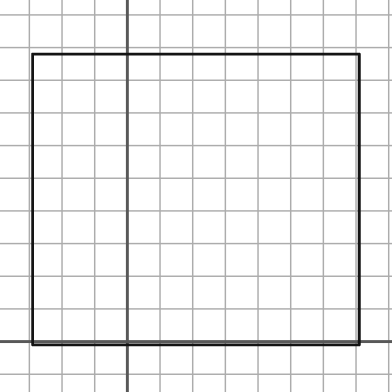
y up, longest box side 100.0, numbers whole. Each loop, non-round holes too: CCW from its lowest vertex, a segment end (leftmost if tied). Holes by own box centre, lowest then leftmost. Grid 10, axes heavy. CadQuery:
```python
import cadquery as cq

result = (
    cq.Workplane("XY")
    .moveTo(-29.0, -1.0)
    .lineTo(71.0, -1.0)
    .lineTo(71.0, 88.0)
    .lineTo(-29.0, 88.0)
    .close()
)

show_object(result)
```